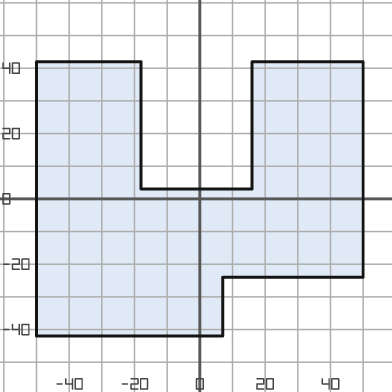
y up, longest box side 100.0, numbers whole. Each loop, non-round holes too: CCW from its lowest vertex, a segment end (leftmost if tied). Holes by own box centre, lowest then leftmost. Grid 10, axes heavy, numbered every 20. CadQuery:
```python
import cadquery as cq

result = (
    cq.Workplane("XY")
    .moveTo(-50.0, -42.0)
    .lineTo(7.0, -42.0)
    .lineTo(7.0, -24.0)
    .lineTo(50.0, -24.0)
    .lineTo(50.0, 42.0)
    .lineTo(16.0, 42.0)
    .lineTo(16.0, 3.0)
    .lineTo(-18.0, 3.0)
    .lineTo(-18.0, 42.0)
    .lineTo(-50.0, 42.0)
    .close()
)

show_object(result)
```